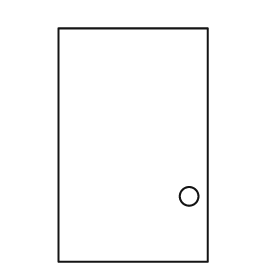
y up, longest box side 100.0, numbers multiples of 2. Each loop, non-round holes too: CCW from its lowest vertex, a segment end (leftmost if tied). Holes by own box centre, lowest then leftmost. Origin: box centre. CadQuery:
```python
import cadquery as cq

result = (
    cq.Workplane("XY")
    .moveTo(-32.0, -50.0)
    .lineTo(32.0, -50.0)
    .lineTo(32.0, 50.0)
    .lineTo(-32.0, 50.0)
    .close()
    .moveTo(24.0, -22.0)
    .circle(4.0)
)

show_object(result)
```